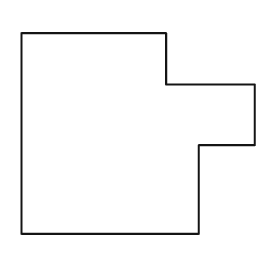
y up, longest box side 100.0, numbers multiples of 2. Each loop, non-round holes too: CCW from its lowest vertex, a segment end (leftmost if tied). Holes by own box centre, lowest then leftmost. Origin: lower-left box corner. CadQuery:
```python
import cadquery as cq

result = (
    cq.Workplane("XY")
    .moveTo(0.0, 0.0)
    .lineTo(76.0, 0.0)
    .lineTo(76.0, 38.0)
    .lineTo(100.0, 38.0)
    .lineTo(100.0, 64.0)
    .lineTo(62.0, 64.0)
    .lineTo(62.0, 86.0)
    .lineTo(0.0, 86.0)
    .close()
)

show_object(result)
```